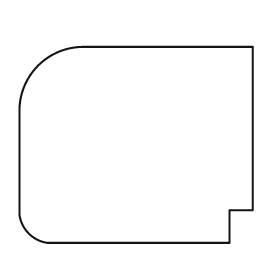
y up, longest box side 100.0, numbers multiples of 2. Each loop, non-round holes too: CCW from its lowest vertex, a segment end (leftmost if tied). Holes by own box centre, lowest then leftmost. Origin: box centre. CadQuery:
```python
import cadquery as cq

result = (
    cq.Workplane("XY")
    .moveTo(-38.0, -42.0)
    .lineTo(40.0, -42.0)
    .lineTo(40.0, -28.0)
    .lineTo(50.0, -28.0)
    .lineTo(50.0, 42.0)
    .lineTo(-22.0, 42.0)
    .threePointArc((-42.0, 34.0), (-50.0, 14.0))
    .lineTo(-50.0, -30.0)
    .threePointArc((-46.0, -38.0), (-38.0, -42.0))
    .close()
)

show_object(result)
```